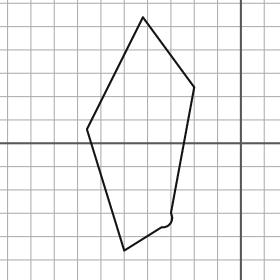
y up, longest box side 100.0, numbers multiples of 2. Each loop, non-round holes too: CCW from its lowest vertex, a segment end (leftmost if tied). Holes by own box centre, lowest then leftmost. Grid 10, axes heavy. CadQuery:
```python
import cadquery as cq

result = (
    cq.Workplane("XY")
    .moveTo(-50.0, -46.0)
    .lineTo(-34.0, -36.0)
    .threePointArc((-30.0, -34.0), (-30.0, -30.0))
    .lineTo(-20.0, 24.0)
    .lineTo(-42.0, 54.0)
    .lineTo(-66.0, 6.0)
    .close()
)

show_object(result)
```